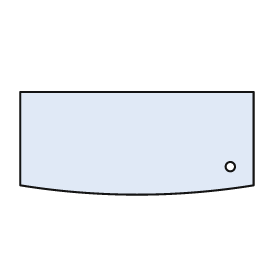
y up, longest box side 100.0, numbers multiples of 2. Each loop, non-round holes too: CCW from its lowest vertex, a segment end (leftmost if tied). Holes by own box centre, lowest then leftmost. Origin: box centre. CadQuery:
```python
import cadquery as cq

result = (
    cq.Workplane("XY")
    .moveTo(-50.0, -18.0)
    .threePointArc((0.0, -22.0), (50.0, -18.0))
    .lineTo(50.0, 22.0)
    .lineTo(-50.0, 22.0)
    .close()
    .moveTo(40.0, -10.0)
    .circle(2.0)
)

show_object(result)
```